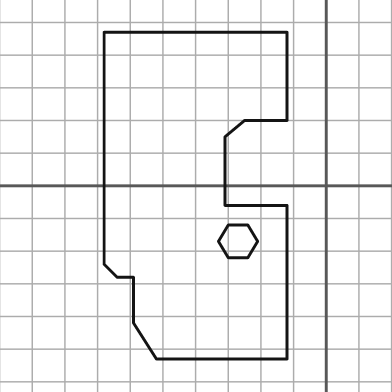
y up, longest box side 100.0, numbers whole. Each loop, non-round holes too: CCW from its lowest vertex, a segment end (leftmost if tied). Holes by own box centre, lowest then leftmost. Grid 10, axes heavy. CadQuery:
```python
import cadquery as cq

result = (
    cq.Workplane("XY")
    .moveTo(-52.0, -53.0)
    .lineTo(-12.0, -53.0)
    .lineTo(-12.0, -6.0)
    .lineTo(-31.0, -6.0)
    .lineTo(-31.0, 15.0)
    .lineTo(-25.0, 20.0)
    .lineTo(-12.0, 20.0)
    .lineTo(-12.0, 47.0)
    .lineTo(-68.0, 47.0)
    .lineTo(-68.0, -24.0)
    .lineTo(-64.0, -28.0)
    .lineTo(-59.0, -28.0)
    .lineTo(-59.0, -42.0)
    .close()
    .moveTo(-30.0, -22.0)
    .lineTo(-24.0, -22.0)
    .lineTo(-21.0, -17.0)
    .lineTo(-24.0, -12.0)
    .lineTo(-30.0, -12.0)
    .lineTo(-33.0, -17.0)
    .close()
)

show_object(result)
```